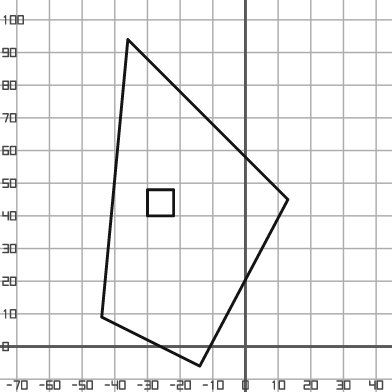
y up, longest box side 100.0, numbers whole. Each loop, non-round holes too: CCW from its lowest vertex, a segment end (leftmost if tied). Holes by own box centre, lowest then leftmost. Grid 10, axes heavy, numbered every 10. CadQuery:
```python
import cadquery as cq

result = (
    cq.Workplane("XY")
    .moveTo(-14.0, -6.0)
    .lineTo(13.0, 45.0)
    .lineTo(-36.0, 94.0)
    .lineTo(-44.0, 9.0)
    .close()
    .moveTo(-30.0, 40.0)
    .lineTo(-22.0, 40.0)
    .lineTo(-22.0, 48.0)
    .lineTo(-30.0, 48.0)
    .close()
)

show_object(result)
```